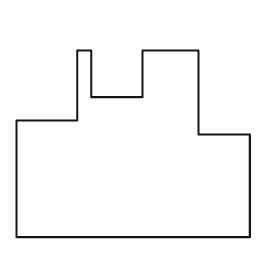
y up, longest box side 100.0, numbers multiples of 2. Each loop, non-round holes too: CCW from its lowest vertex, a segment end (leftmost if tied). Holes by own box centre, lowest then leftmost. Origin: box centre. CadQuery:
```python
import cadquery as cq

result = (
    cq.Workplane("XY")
    .moveTo(-50.0, -40.0)
    .lineTo(50.0, -40.0)
    .lineTo(50.0, 4.0)
    .lineTo(28.0, 4.0)
    .lineTo(28.0, 40.0)
    .lineTo(4.0, 40.0)
    .lineTo(4.0, 20.0)
    .lineTo(-18.0, 20.0)
    .lineTo(-18.0, 40.0)
    .lineTo(-24.0, 40.0)
    .lineTo(-24.0, 10.0)
    .lineTo(-50.0, 10.0)
    .close()
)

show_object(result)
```